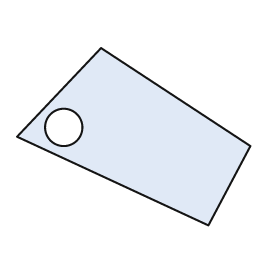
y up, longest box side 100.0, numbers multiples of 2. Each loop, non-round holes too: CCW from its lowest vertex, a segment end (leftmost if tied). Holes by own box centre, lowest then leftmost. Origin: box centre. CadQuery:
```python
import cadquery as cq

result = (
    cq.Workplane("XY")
    .moveTo(32.0, -38.0)
    .lineTo(50.0, -4.0)
    .lineTo(-14.0, 38.0)
    .lineTo(-50.0, 0.0)
    .close()
    .moveTo(-30.0, 4.0)
    .circle(8.0)
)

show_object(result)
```